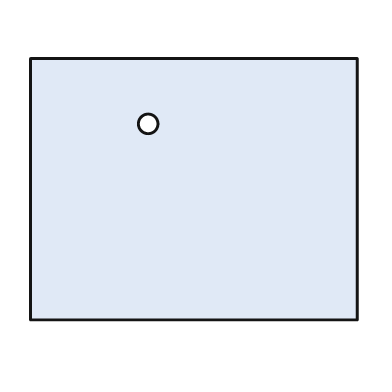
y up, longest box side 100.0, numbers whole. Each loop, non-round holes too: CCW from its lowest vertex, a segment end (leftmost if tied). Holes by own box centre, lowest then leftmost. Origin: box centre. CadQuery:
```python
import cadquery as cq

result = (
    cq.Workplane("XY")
    .moveTo(-50.0, -40.0)
    .lineTo(50.0, -40.0)
    .lineTo(50.0, 40.0)
    .lineTo(-50.0, 40.0)
    .close()
    .moveTo(-14.0, 20.0)
    .circle(3.0)
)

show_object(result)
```